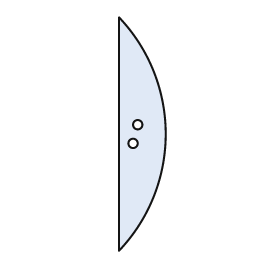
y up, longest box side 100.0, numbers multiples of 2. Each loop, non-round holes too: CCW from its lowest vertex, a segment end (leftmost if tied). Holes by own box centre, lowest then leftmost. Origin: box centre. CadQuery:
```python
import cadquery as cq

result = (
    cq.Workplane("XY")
    .moveTo(-10.0, -50.0)
    .threePointArc((10.0, 0.0), (-10.0, 50.0))
    .close()
    .moveTo(-4.0, -4.0)
    .circle(2.0)
    .moveTo(-2.0, 4.0)
    .circle(2.0)
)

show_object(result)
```